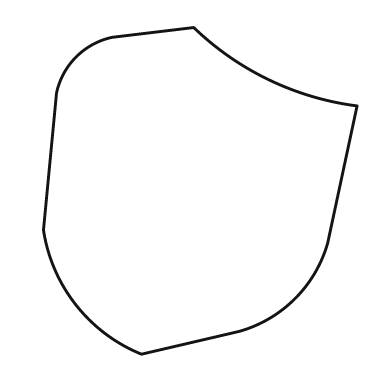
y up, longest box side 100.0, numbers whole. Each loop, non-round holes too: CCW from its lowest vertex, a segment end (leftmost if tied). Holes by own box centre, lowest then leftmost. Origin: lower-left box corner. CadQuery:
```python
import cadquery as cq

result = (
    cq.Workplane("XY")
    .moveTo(30.0, 0.0)
    .lineTo(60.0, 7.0)
    .threePointArc((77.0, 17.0), (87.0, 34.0))
    .lineTo(96.0, 76.0)
    .threePointArc((69.0, 84.0), (46.0, 100.0))
    .lineTo(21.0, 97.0)
    .threePointArc((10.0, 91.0), (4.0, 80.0))
    .lineTo(0.0, 38.0)
    .threePointArc((10.0, 15.0), (30.0, 0.0))
    .close()
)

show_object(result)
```